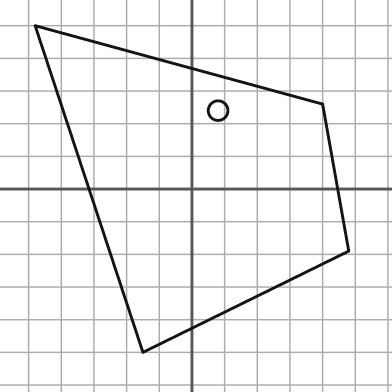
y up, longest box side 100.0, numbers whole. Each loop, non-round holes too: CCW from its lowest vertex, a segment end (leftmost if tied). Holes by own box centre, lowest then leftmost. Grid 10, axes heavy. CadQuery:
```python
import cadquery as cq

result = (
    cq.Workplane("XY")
    .moveTo(-15.0, -50.0)
    .lineTo(48.0, -19.0)
    .lineTo(40.0, 26.0)
    .lineTo(-48.0, 50.0)
    .close()
    .moveTo(8.0, 24.0)
    .circle(3.0)
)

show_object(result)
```